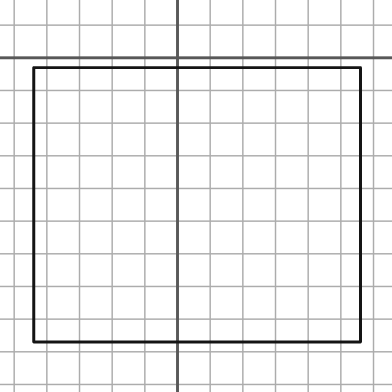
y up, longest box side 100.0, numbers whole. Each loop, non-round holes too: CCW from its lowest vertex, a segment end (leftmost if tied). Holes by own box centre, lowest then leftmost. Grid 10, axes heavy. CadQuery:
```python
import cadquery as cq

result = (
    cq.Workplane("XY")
    .moveTo(-44.0, -87.0)
    .lineTo(56.0, -87.0)
    .lineTo(56.0, -3.0)
    .lineTo(-44.0, -3.0)
    .close()
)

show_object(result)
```